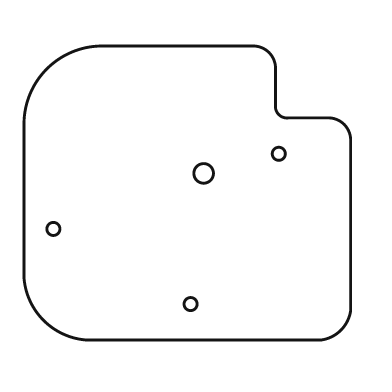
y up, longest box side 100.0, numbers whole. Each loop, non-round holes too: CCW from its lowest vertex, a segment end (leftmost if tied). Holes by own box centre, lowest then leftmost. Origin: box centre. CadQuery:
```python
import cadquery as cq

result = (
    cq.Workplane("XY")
    .moveTo(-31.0, -45.0)
    .lineTo(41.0, -45.0)
    .threePointArc((47.0, -42.0), (50.0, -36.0))
    .lineTo(50.0, 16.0)
    .threePointArc((48.0, 21.0), (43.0, 23.0))
    .lineTo(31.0, 23.0)
    .threePointArc((28.0, 24.0), (27.0, 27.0))
    .lineTo(27.0, 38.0)
    .threePointArc((25.0, 43.0), (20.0, 45.0))
    .lineTo(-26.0, 45.0)
    .threePointArc((-43.0, 38.0), (-50.0, 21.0))
    .lineTo(-50.0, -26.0)
    .threePointArc((-44.0, -39.0), (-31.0, -45.0))
    .close()
    .moveTo(1.0, -34.0)
    .circle(2.0)
    .moveTo(-41.0, -11.0)
    .circle(2.0)
    .moveTo(5.0, 6.0)
    .circle(3.0)
    .moveTo(28.0, 12.0)
    .circle(2.0)
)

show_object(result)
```